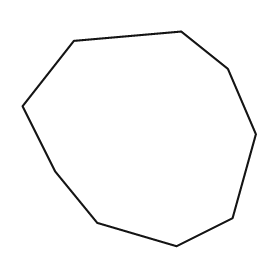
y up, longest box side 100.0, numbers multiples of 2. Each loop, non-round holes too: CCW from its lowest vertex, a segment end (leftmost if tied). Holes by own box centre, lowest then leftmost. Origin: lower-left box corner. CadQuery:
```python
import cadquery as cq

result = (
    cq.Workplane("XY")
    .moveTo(66.0, 0.0)
    .lineTo(90.0, 12.0)
    .lineTo(100.0, 48.0)
    .lineTo(88.0, 76.0)
    .lineTo(68.0, 92.0)
    .lineTo(22.0, 88.0)
    .lineTo(0.0, 60.0)
    .lineTo(14.0, 32.0)
    .lineTo(32.0, 10.0)
    .close()
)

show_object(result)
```